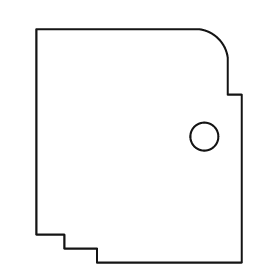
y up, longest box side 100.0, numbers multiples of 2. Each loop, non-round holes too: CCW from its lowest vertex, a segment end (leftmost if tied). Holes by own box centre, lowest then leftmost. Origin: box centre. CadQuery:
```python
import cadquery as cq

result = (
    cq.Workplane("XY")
    .moveTo(-18.0, -50.0)
    .lineTo(44.0, -50.0)
    .lineTo(44.0, 22.0)
    .lineTo(38.0, 22.0)
    .lineTo(38.0, 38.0)
    .threePointArc((34.0, 46.0), (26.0, 50.0))
    .lineTo(-44.0, 50.0)
    .lineTo(-44.0, -38.0)
    .lineTo(-32.0, -38.0)
    .lineTo(-32.0, -44.0)
    .lineTo(-18.0, -44.0)
    .close()
    .moveTo(28.0, 4.0)
    .circle(6.0)
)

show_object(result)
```